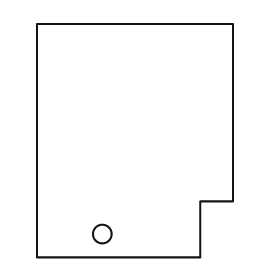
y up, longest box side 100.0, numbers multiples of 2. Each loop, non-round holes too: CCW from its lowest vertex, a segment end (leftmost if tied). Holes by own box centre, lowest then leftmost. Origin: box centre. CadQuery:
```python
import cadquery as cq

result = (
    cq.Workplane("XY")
    .moveTo(-42.0, -50.0)
    .lineTo(28.0, -50.0)
    .lineTo(28.0, -26.0)
    .lineTo(42.0, -26.0)
    .lineTo(42.0, 50.0)
    .lineTo(-42.0, 50.0)
    .close()
    .moveTo(-14.0, -40.0)
    .circle(4.0)
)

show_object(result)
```